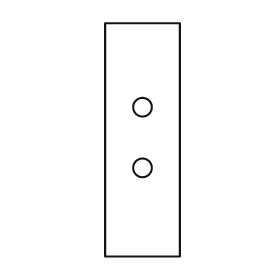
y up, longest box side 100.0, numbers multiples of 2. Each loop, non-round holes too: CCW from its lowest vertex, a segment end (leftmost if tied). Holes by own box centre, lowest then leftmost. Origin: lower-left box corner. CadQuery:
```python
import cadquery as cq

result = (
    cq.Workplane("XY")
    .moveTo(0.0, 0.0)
    .lineTo(32.0, 0.0)
    .lineTo(32.0, 100.0)
    .lineTo(0.0, 100.0)
    .close()
    .moveTo(16.0, 38.0)
    .circle(4.0)
    .moveTo(16.0, 64.0)
    .circle(4.0)
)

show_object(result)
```